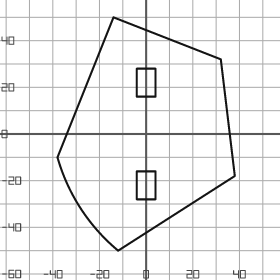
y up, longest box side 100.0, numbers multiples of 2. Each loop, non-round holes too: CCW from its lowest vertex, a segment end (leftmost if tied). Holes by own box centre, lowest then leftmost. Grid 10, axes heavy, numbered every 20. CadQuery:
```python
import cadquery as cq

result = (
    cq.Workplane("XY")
    .moveTo(-12.0, -50.0)
    .lineTo(38.0, -18.0)
    .lineTo(32.0, 32.0)
    .lineTo(-14.0, 50.0)
    .lineTo(-38.0, -10.0)
    .threePointArc((-28.0, -32.0), (-12.0, -50.0))
    .close()
    .moveTo(-4.0, -28.0)
    .lineTo(4.0, -28.0)
    .lineTo(4.0, -16.0)
    .lineTo(-4.0, -16.0)
    .close()
    .moveTo(-4.0, 16.0)
    .lineTo(4.0, 16.0)
    .lineTo(4.0, 28.0)
    .lineTo(-4.0, 28.0)
    .close()
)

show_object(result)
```